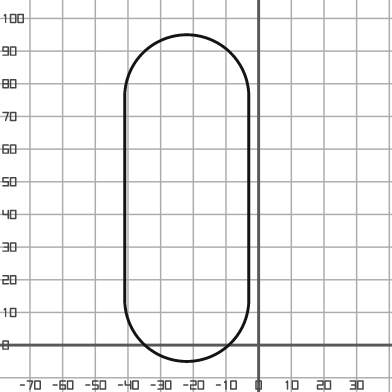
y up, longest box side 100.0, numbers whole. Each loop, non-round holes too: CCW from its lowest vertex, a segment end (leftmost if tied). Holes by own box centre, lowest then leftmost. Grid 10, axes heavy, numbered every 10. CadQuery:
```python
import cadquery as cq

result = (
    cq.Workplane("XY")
    .moveTo(-41.0, 14.0)
    .threePointArc((-22.0, -5.0), (-3.0, 14.0))
    .lineTo(-3.0, 76.0)
    .threePointArc((-22.0, 95.0), (-41.0, 76.0))
    .close()
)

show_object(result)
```